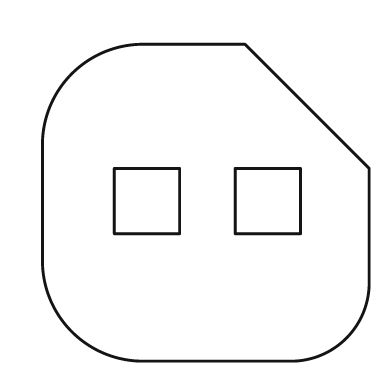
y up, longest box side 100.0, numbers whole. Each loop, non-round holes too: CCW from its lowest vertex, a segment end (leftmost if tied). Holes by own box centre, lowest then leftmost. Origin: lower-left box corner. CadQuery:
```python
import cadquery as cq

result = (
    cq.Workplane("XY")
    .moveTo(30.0, 0.0)
    .lineTo(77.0, 0.0)
    .threePointArc((93.0, 7.0), (100.0, 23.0))
    .lineTo(100.0, 59.0)
    .lineTo(62.0, 97.0)
    .lineTo(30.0, 97.0)
    .threePointArc((9.0, 88.0), (0.0, 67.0))
    .lineTo(0.0, 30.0)
    .threePointArc((9.0, 9.0), (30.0, 0.0))
    .close()
    .moveTo(22.0, 39.0)
    .lineTo(42.0, 39.0)
    .lineTo(42.0, 59.0)
    .lineTo(22.0, 59.0)
    .close()
    .moveTo(59.0, 39.0)
    .lineTo(79.0, 39.0)
    .lineTo(79.0, 59.0)
    .lineTo(59.0, 59.0)
    .close()
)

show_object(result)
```